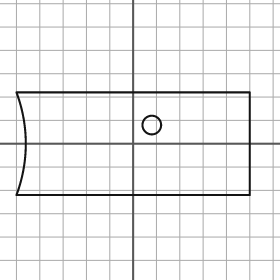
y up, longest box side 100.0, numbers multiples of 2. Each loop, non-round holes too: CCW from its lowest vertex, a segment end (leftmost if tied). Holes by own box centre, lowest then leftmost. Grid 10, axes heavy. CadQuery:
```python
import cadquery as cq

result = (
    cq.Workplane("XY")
    .moveTo(-50.0, -22.0)
    .lineTo(50.0, -22.0)
    .lineTo(50.0, 22.0)
    .lineTo(-50.0, 22.0)
    .threePointArc((-46.0, 0.0), (-50.0, -22.0))
    .close()
    .moveTo(8.0, 8.0)
    .circle(4.0)
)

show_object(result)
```